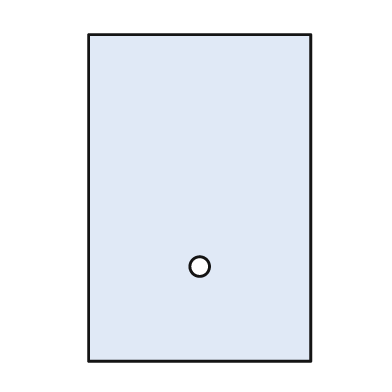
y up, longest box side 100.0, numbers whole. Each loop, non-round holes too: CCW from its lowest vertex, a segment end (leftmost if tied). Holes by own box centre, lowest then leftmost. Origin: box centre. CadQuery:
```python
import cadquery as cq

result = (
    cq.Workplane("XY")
    .moveTo(-34.0, -50.0)
    .lineTo(34.0, -50.0)
    .lineTo(34.0, 50.0)
    .lineTo(-34.0, 50.0)
    .close()
    .moveTo(0.0, -21.0)
    .circle(3.0)
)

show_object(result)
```